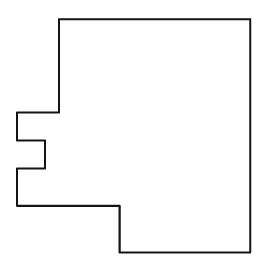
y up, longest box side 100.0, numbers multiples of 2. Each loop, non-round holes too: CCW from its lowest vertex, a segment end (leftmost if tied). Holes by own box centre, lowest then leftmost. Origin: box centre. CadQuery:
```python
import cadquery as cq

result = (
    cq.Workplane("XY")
    .moveTo(-6.0, -50.0)
    .lineTo(50.0, -50.0)
    .lineTo(50.0, 50.0)
    .lineTo(-32.0, 50.0)
    .lineTo(-32.0, 10.0)
    .lineTo(-50.0, 10.0)
    .lineTo(-50.0, -2.0)
    .lineTo(-38.0, -2.0)
    .lineTo(-38.0, -14.0)
    .lineTo(-50.0, -14.0)
    .lineTo(-50.0, -30.0)
    .lineTo(-6.0, -30.0)
    .close()
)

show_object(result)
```